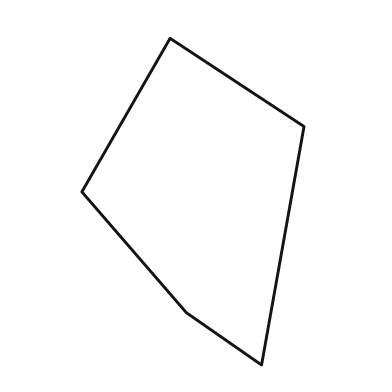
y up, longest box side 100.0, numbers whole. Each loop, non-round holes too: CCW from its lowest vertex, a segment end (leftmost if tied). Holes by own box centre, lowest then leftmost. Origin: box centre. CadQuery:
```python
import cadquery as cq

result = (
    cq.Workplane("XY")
    .moveTo(21.0, -50.0)
    .lineTo(34.0, 23.0)
    .lineTo(-7.0, 50.0)
    .lineTo(-34.0, 3.0)
    .lineTo(-2.0, -34.0)
    .close()
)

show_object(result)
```